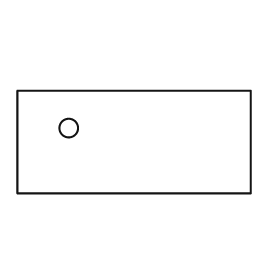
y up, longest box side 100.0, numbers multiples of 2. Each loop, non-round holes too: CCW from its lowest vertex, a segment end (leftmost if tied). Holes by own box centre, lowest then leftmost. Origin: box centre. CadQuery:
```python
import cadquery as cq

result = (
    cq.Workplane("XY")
    .moveTo(-50.0, -22.0)
    .lineTo(50.0, -22.0)
    .lineTo(50.0, 22.0)
    .lineTo(-50.0, 22.0)
    .close()
    .moveTo(-28.0, 6.0)
    .circle(4.0)
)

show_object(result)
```